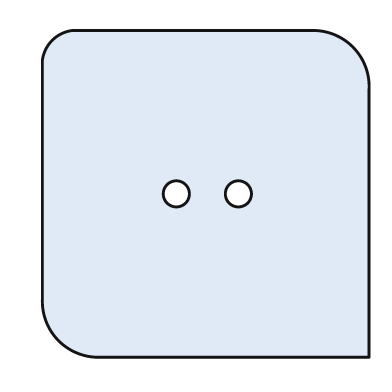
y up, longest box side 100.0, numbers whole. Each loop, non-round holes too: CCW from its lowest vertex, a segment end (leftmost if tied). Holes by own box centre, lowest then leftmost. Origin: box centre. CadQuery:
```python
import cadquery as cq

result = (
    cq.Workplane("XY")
    .moveTo(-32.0, -50.0)
    .lineTo(50.0, -50.0)
    .lineTo(50.0, 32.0)
    .threePointArc((45.0, 45.0), (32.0, 50.0))
    .lineTo(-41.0, 50.0)
    .threePointArc((-47.0, 47.0), (-50.0, 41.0))
    .lineTo(-50.0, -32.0)
    .threePointArc((-45.0, -45.0), (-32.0, -50.0))
    .close()
    .moveTo(-9.0, 0.0)
    .circle(4.0)
    .moveTo(10.0, 0.0)
    .circle(4.0)
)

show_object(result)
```